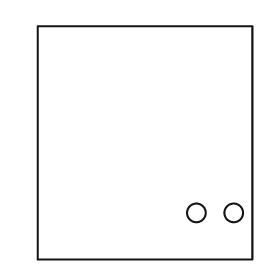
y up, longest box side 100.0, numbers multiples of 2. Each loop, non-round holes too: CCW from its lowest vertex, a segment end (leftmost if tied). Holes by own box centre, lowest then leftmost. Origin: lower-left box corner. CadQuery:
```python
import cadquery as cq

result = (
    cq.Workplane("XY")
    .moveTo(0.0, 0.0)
    .lineTo(92.0, 0.0)
    .lineTo(92.0, 100.0)
    .lineTo(0.0, 100.0)
    .close()
    .moveTo(68.0, 20.0)
    .circle(4.0)
    .moveTo(84.0, 20.0)
    .circle(4.0)
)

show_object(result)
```